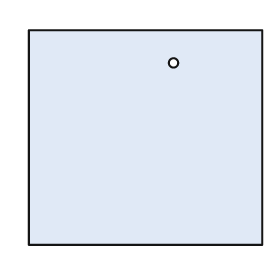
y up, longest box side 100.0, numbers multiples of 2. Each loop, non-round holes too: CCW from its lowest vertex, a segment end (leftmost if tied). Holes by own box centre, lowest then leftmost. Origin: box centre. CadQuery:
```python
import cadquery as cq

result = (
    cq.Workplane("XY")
    .moveTo(-50.0, -46.0)
    .lineTo(50.0, -46.0)
    .lineTo(50.0, 46.0)
    .lineTo(-50.0, 46.0)
    .close()
    .moveTo(12.0, 32.0)
    .circle(2.0)
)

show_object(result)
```